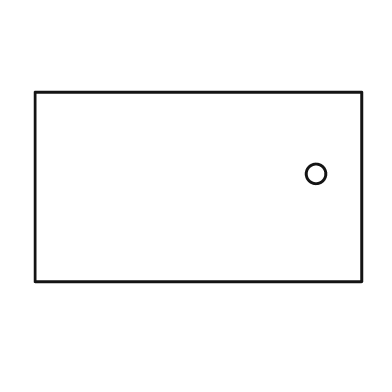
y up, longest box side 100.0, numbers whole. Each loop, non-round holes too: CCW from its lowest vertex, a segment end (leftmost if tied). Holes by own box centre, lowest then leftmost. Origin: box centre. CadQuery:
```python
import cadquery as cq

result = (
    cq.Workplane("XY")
    .moveTo(-50.0, -29.0)
    .lineTo(50.0, -29.0)
    .lineTo(50.0, 29.0)
    .lineTo(-50.0, 29.0)
    .close()
    .moveTo(36.0, 4.0)
    .circle(3.0)
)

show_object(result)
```